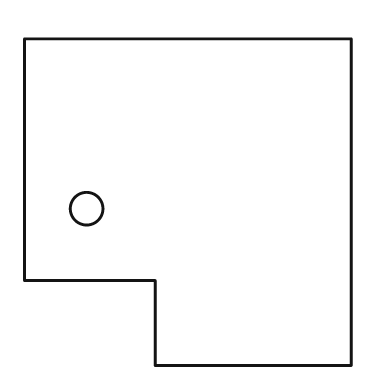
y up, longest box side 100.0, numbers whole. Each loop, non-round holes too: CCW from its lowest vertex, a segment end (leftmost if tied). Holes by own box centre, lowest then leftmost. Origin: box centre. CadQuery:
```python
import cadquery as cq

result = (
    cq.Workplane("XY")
    .moveTo(-10.0, -50.0)
    .lineTo(50.0, -50.0)
    .lineTo(50.0, 50.0)
    .lineTo(-50.0, 50.0)
    .lineTo(-50.0, -24.0)
    .lineTo(-10.0, -24.0)
    .close()
    .moveTo(-31.0, -2.0)
    .circle(5.0)
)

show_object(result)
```